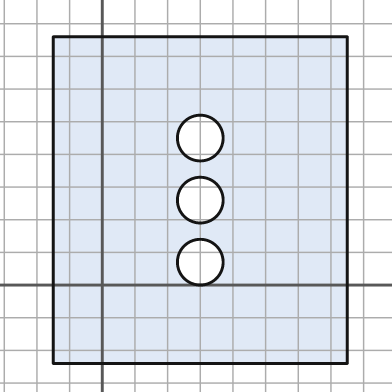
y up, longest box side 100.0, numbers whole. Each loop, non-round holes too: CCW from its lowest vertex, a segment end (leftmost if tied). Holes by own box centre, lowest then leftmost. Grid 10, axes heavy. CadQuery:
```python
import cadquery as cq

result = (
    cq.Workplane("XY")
    .moveTo(-15.0, -24.0)
    .lineTo(75.0, -24.0)
    .lineTo(75.0, 76.0)
    .lineTo(-15.0, 76.0)
    .close()
    .moveTo(30.0, 7.0)
    .circle(7.0)
    .moveTo(30.0, 26.0)
    .circle(7.0)
    .moveTo(30.0, 45.0)
    .circle(7.0)
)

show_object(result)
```